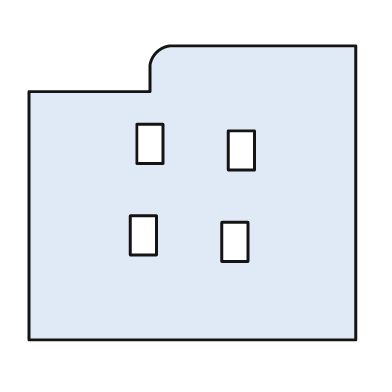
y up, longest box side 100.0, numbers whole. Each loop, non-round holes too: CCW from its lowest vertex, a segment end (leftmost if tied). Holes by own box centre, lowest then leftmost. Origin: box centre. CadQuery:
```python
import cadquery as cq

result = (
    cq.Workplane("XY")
    .moveTo(-50.0, -45.0)
    .lineTo(50.0, -45.0)
    .lineTo(50.0, 45.0)
    .lineTo(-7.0, 45.0)
    .threePointArc((-11.0, 43.0), (-13.0, 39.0))
    .lineTo(-13.0, 31.0)
    .lineTo(-50.0, 31.0)
    .close()
    .moveTo(9.0, -21.0)
    .lineTo(17.0, -21.0)
    .lineTo(17.0, -9.0)
    .lineTo(9.0, -9.0)
    .close()
    .moveTo(-19.0, -19.0)
    .lineTo(-11.0, -19.0)
    .lineTo(-11.0, -7.0)
    .lineTo(-19.0, -7.0)
    .close()
    .moveTo(11.0, 7.0)
    .lineTo(19.0, 7.0)
    .lineTo(19.0, 19.0)
    .lineTo(11.0, 19.0)
    .close()
    .moveTo(-17.0, 9.0)
    .lineTo(-9.0, 9.0)
    .lineTo(-9.0, 21.0)
    .lineTo(-17.0, 21.0)
    .close()
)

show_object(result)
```